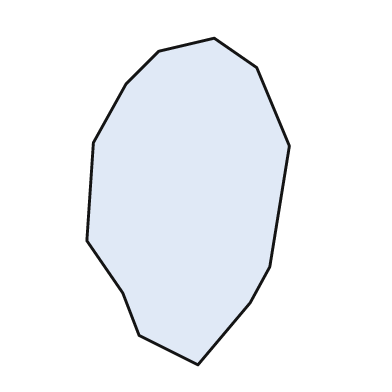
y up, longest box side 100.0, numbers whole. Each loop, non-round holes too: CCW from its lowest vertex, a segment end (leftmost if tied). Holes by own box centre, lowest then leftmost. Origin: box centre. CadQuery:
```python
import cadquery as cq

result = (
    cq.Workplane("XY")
    .moveTo(3.0, -50.0)
    .lineTo(19.0, -31.0)
    .lineTo(25.0, -20.0)
    .lineTo(31.0, 17.0)
    .lineTo(21.0, 41.0)
    .lineTo(8.0, 50.0)
    .lineTo(-9.0, 46.0)
    .lineTo(-19.0, 36.0)
    .lineTo(-29.0, 18.0)
    .lineTo(-31.0, -12.0)
    .lineTo(-20.0, -28.0)
    .lineTo(-15.0, -41.0)
    .close()
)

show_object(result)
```